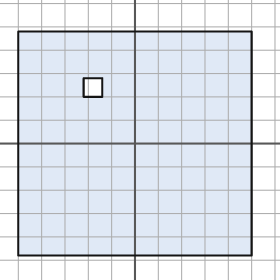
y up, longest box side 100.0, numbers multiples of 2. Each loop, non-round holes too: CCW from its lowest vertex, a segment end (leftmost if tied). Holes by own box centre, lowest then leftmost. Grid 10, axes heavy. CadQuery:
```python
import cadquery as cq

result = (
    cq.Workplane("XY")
    .moveTo(-50.0, -48.0)
    .lineTo(50.0, -48.0)
    .lineTo(50.0, 48.0)
    .lineTo(-50.0, 48.0)
    .close()
    .moveTo(-22.0, 20.0)
    .lineTo(-14.0, 20.0)
    .lineTo(-14.0, 28.0)
    .lineTo(-22.0, 28.0)
    .close()
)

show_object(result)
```